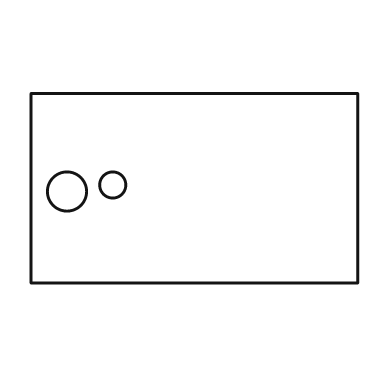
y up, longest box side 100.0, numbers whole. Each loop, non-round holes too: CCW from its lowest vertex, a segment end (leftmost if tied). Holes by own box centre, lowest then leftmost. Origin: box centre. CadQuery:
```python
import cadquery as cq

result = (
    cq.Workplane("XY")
    .moveTo(-50.0, -29.0)
    .lineTo(50.0, -29.0)
    .lineTo(50.0, 29.0)
    .lineTo(-50.0, 29.0)
    .close()
    .moveTo(-39.0, -1.0)
    .circle(6.0)
    .moveTo(-25.0, 1.0)
    .circle(4.0)
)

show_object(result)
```